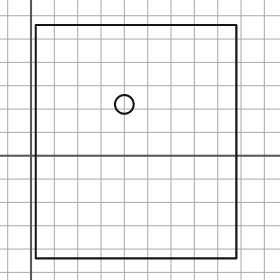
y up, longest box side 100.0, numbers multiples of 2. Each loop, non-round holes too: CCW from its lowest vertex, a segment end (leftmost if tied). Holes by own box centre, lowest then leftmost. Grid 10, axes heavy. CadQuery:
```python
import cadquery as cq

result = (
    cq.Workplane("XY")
    .moveTo(2.0, -44.0)
    .lineTo(88.0, -44.0)
    .lineTo(88.0, 56.0)
    .lineTo(2.0, 56.0)
    .close()
    .moveTo(40.0, 22.0)
    .circle(4.0)
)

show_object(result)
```